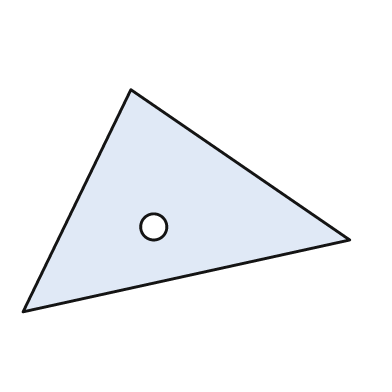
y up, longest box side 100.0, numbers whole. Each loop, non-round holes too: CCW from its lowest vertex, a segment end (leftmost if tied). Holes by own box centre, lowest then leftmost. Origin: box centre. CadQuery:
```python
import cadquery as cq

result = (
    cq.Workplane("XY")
    .moveTo(-50.0, -34.0)
    .lineTo(50.0, -12.0)
    .lineTo(-17.0, 34.0)
    .close()
    .moveTo(-10.0, -8.0)
    .circle(4.0)
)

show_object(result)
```